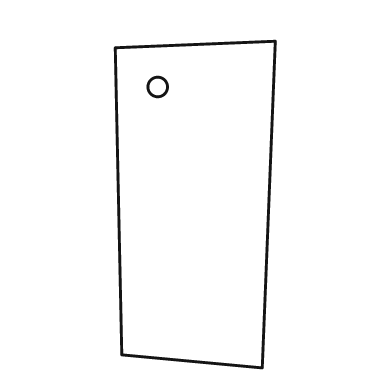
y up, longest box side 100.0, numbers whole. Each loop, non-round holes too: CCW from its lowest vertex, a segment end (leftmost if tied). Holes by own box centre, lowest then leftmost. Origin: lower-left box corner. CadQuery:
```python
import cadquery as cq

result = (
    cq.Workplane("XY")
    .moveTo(45.0, 0.0)
    .lineTo(49.0, 100.0)
    .lineTo(0.0, 98.0)
    .lineTo(2.0, 4.0)
    .close()
    .moveTo(13.0, 86.0)
    .circle(3.0)
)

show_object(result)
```